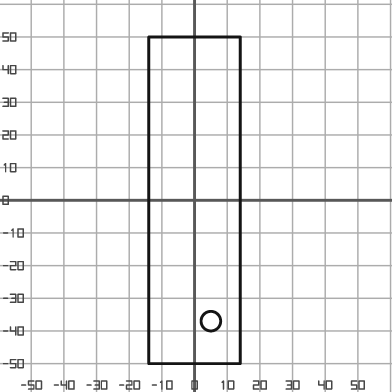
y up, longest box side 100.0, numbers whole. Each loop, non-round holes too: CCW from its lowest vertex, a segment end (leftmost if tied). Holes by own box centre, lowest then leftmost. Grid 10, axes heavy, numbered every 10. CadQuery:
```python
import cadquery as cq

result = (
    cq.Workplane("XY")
    .moveTo(-14.0, -50.0)
    .lineTo(14.0, -50.0)
    .lineTo(14.0, 50.0)
    .lineTo(-14.0, 50.0)
    .close()
    .moveTo(5.0, -37.0)
    .circle(3.0)
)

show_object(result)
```